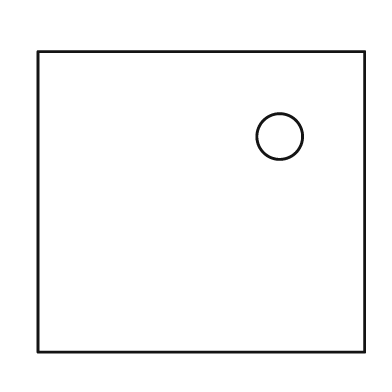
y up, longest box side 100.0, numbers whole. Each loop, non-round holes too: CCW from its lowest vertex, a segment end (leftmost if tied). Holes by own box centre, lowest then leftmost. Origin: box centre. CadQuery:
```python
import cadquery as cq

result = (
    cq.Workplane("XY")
    .moveTo(-50.0, -46.0)
    .lineTo(50.0, -46.0)
    .lineTo(50.0, 46.0)
    .lineTo(-50.0, 46.0)
    .close()
    .moveTo(24.0, 20.0)
    .circle(7.0)
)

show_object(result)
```